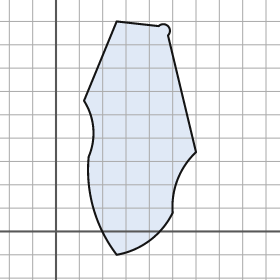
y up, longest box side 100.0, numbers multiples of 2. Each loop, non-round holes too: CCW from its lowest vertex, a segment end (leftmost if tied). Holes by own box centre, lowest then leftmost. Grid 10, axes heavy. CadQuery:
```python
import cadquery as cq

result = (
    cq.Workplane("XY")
    .moveTo(26.0, -10.0)
    .threePointArc((40.0, -4.0), (50.0, 8.0))
    .threePointArc((52.0, 22.0), (60.0, 34.0))
    .lineTo(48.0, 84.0)
    .threePointArc((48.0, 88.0), (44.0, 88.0))
    .lineTo(26.0, 90.0)
    .lineTo(12.0, 56.0)
    .threePointArc((16.0, 44.0), (14.0, 32.0))
    .threePointArc((16.0, 10.0), (26.0, -10.0))
    .close()
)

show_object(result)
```